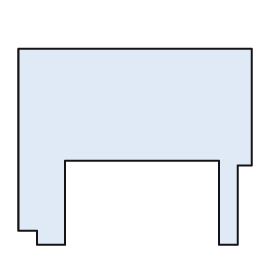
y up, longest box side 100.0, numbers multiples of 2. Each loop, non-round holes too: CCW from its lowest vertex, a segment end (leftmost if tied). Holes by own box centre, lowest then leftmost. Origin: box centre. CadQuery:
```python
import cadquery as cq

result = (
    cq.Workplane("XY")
    .moveTo(-42.0, -42.0)
    .lineTo(-30.0, -42.0)
    .lineTo(-30.0, -6.0)
    .lineTo(36.0, -6.0)
    .lineTo(36.0, -42.0)
    .lineTo(44.0, -42.0)
    .lineTo(44.0, -8.0)
    .lineTo(50.0, -8.0)
    .lineTo(50.0, 42.0)
    .lineTo(-50.0, 42.0)
    .lineTo(-50.0, -36.0)
    .lineTo(-42.0, -36.0)
    .close()
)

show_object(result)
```